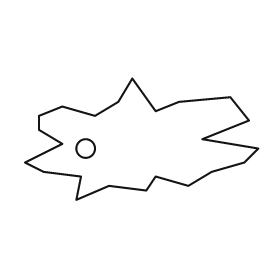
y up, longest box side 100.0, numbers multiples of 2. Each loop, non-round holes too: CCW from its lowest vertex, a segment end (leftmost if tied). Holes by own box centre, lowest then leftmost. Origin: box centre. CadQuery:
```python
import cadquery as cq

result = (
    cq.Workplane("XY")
    .moveTo(-28.0, -26.0)
    .lineTo(-14.0, -20.0)
    .lineTo(2.0, -22.0)
    .lineTo(6.0, -16.0)
    .lineTo(20.0, -20.0)
    .lineTo(30.0, -14.0)
    .lineTo(44.0, -10.0)
    .lineTo(50.0, -4.0)
    .lineTo(26.0, 0.0)
    .lineTo(46.0, 8.0)
    .lineTo(38.0, 18.0)
    .lineTo(16.0, 16.0)
    .lineTo(6.0, 12.0)
    .lineTo(-4.0, 26.0)
    .lineTo(-10.0, 16.0)
    .lineTo(-20.0, 10.0)
    .lineTo(-34.0, 14.0)
    .lineTo(-44.0, 10.0)
    .lineTo(-44.0, 4.0)
    .lineTo(-34.0, -2.0)
    .lineTo(-50.0, -10.0)
    .lineTo(-42.0, -14.0)
    .lineTo(-26.0, -16.0)
    .close()
    .moveTo(-24.0, -4.0)
    .circle(4.0)
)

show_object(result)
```